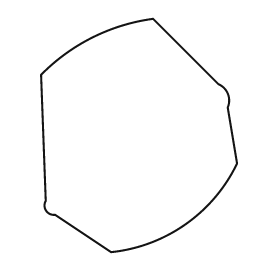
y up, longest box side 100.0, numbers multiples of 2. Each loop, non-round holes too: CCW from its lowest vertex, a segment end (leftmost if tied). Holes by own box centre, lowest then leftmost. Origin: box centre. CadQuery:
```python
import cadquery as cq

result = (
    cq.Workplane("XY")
    .moveTo(-12.0, -50.0)
    .threePointArc((20.0, -38.0), (42.0, -12.0))
    .lineTo(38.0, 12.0)
    .threePointArc((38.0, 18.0), (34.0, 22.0))
    .lineTo(6.0, 50.0)
    .threePointArc((-20.0, 42.0), (-42.0, 26.0))
    .lineTo(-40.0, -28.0)
    .threePointArc((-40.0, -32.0), (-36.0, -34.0))
    .close()
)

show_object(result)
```